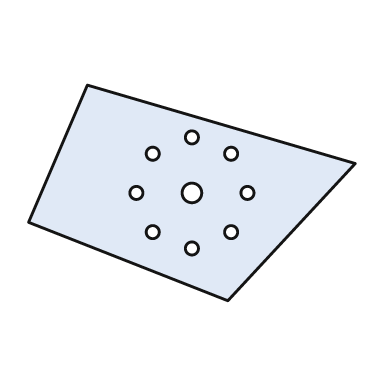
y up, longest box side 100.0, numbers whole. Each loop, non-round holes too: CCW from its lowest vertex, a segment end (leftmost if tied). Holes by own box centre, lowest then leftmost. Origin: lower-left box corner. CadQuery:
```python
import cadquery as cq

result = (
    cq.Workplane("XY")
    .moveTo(61.0, 0.0)
    .lineTo(100.0, 42.0)
    .lineTo(18.0, 66.0)
    .lineTo(0.0, 24.0)
    .close()
    .moveTo(50.0, 16.0)
    .circle(2.0)
    .moveTo(38.0, 21.0)
    .circle(2.0)
    .moveTo(62.0, 21.0)
    .circle(2.0)
    .moveTo(33.0, 33.0)
    .circle(2.0)
    .moveTo(50.0, 33.0)
    .circle(3.0)
    .moveTo(67.0, 33.0)
    .circle(2.0)
    .moveTo(38.0, 45.0)
    .circle(2.0)
    .moveTo(62.0, 45.0)
    .circle(2.0)
    .moveTo(50.0, 50.0)
    .circle(2.0)
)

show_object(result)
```